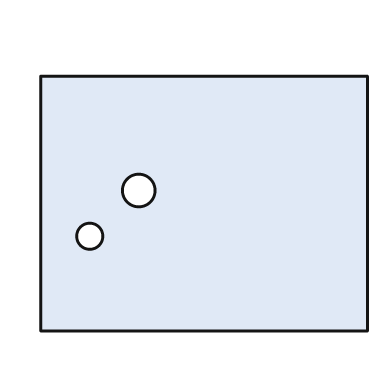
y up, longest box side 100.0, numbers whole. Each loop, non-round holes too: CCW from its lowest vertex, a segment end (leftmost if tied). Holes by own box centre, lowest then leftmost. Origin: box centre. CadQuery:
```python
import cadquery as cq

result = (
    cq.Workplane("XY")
    .moveTo(-50.0, -39.0)
    .lineTo(50.0, -39.0)
    .lineTo(50.0, 39.0)
    .lineTo(-50.0, 39.0)
    .close()
    .moveTo(-35.0, -10.0)
    .circle(4.0)
    .moveTo(-20.0, 4.0)
    .circle(5.0)
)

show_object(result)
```